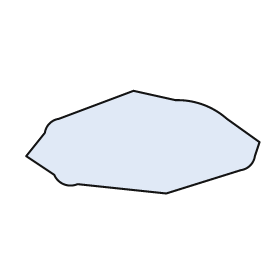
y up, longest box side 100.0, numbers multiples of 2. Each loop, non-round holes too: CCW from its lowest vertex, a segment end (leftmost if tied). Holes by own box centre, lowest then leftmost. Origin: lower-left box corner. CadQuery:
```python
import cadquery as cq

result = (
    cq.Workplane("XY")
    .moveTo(60.0, 0.0)
    .lineTo(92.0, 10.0)
    .threePointArc((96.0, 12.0), (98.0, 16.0))
    .lineTo(100.0, 22.0)
    .lineTo(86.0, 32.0)
    .threePointArc((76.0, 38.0), (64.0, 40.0))
    .lineTo(46.0, 44.0)
    .lineTo(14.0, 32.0)
    .threePointArc((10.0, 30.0), (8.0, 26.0))
    .lineTo(0.0, 16.0)
    .lineTo(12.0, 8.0)
    .threePointArc((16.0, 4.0), (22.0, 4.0))
    .close()
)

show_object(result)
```